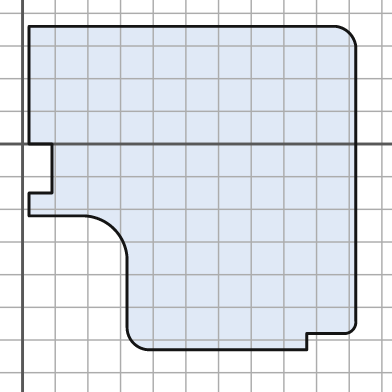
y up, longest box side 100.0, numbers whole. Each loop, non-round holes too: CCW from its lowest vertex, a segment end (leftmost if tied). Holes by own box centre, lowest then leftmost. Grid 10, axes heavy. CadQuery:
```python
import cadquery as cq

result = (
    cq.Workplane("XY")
    .moveTo(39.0, -63.0)
    .lineTo(87.0, -63.0)
    .lineTo(87.0, -58.0)
    .lineTo(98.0, -58.0)
    .threePointArc((101.0, -57.0), (102.0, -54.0))
    .lineTo(102.0, 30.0)
    .threePointArc((100.0, 34.0), (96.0, 36.0))
    .lineTo(2.0, 36.0)
    .lineTo(2.0, 0.0)
    .lineTo(9.0, 0.0)
    .lineTo(9.0, -15.0)
    .lineTo(2.0, -15.0)
    .lineTo(2.0, -22.0)
    .lineTo(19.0, -22.0)
    .threePointArc((28.0, -26.0), (32.0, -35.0))
    .lineTo(32.0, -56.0)
    .threePointArc((34.0, -61.0), (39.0, -63.0))
    .close()
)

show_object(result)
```